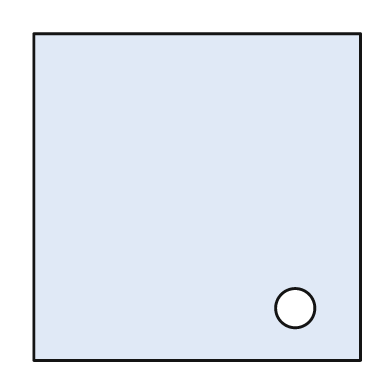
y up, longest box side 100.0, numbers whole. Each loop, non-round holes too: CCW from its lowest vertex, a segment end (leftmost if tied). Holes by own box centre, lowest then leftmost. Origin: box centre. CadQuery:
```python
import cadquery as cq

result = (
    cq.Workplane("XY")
    .moveTo(-50.0, -50.0)
    .lineTo(50.0, -50.0)
    .lineTo(50.0, 50.0)
    .lineTo(-50.0, 50.0)
    .close()
    .moveTo(30.0, -34.0)
    .circle(6.0)
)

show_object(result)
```